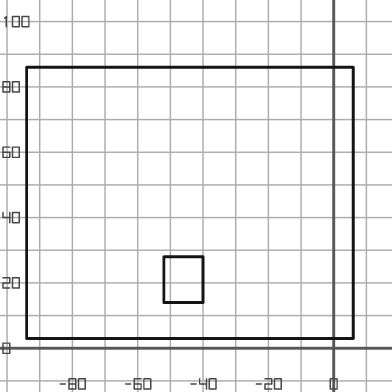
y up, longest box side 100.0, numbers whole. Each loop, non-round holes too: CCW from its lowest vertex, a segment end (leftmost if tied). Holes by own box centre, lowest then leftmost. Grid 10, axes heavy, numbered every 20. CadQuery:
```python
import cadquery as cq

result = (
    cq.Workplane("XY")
    .moveTo(-94.0, 3.0)
    .lineTo(6.0, 3.0)
    .lineTo(6.0, 86.0)
    .lineTo(-94.0, 86.0)
    .close()
    .moveTo(-52.0, 14.0)
    .lineTo(-40.0, 14.0)
    .lineTo(-40.0, 28.0)
    .lineTo(-52.0, 28.0)
    .close()
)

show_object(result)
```